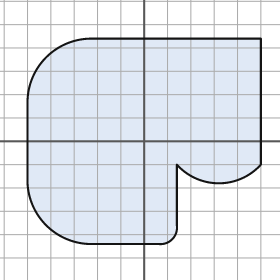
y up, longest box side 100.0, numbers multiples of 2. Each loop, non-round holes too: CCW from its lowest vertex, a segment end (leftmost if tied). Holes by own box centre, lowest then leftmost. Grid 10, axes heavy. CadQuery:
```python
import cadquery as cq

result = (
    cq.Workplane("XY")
    .moveTo(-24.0, -44.0)
    .lineTo(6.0, -44.0)
    .threePointArc((12.0, -42.0), (14.0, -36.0))
    .lineTo(14.0, -10.0)
    .threePointArc((32.0, -18.0), (50.0, -10.0))
    .lineTo(50.0, 44.0)
    .lineTo(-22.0, 44.0)
    .threePointArc((-42.0, 36.0), (-50.0, 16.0))
    .lineTo(-50.0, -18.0)
    .threePointArc((-42.0, -36.0), (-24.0, -44.0))
    .close()
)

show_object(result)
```